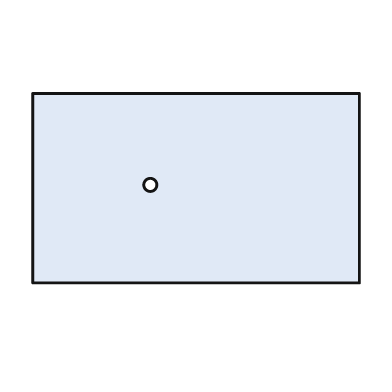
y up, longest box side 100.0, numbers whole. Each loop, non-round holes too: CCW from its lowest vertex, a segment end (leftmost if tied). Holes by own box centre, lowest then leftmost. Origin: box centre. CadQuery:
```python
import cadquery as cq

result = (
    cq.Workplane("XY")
    .moveTo(-50.0, -29.0)
    .lineTo(50.0, -29.0)
    .lineTo(50.0, 29.0)
    .lineTo(-50.0, 29.0)
    .close()
    .moveTo(-14.0, 1.0)
    .circle(2.0)
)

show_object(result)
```